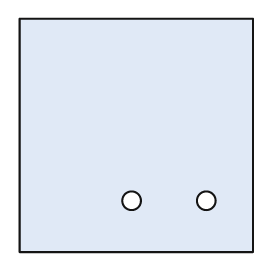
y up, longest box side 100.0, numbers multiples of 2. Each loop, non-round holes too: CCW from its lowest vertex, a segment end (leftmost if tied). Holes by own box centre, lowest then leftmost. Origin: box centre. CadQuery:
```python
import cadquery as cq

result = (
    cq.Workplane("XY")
    .moveTo(-50.0, -50.0)
    .lineTo(50.0, -50.0)
    .lineTo(50.0, 50.0)
    .lineTo(-50.0, 50.0)
    .close()
    .moveTo(-2.0, -28.0)
    .circle(4.0)
    .moveTo(30.0, -28.0)
    .circle(4.0)
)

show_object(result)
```